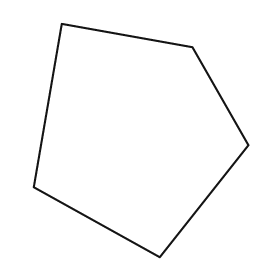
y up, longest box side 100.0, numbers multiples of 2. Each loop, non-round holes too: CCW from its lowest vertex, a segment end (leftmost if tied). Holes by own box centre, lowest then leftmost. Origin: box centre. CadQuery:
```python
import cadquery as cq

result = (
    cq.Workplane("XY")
    .moveTo(8.0, -50.0)
    .lineTo(46.0, -2.0)
    .lineTo(22.0, 40.0)
    .lineTo(-34.0, 50.0)
    .lineTo(-46.0, -20.0)
    .close()
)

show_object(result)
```